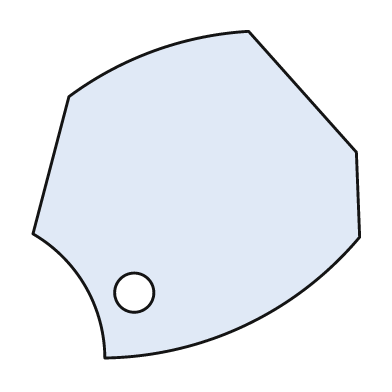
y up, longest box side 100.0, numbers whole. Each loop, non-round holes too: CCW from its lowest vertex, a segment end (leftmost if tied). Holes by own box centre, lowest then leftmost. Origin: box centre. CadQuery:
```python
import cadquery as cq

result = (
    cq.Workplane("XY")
    .moveTo(-28.0, -50.0)
    .threePointArc((15.0, -40.0), (50.0, -13.0))
    .lineTo(49.0, 13.0)
    .lineTo(16.0, 50.0)
    .threePointArc((-13.0, 44.0), (-39.0, 30.0))
    .lineTo(-50.0, -12.0)
    .threePointArc((-34.0, -28.0), (-28.0, -50.0))
    .close()
    .moveTo(-19.0, -30.0)
    .circle(6.0)
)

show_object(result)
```